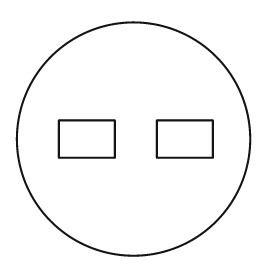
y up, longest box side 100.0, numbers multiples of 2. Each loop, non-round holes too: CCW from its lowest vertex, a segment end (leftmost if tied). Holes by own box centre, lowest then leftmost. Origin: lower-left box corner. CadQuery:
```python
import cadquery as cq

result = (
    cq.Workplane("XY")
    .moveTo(50.0, 50.0)
    .circle(50.0)
    .moveTo(18.0, 42.0)
    .lineTo(42.0, 42.0)
    .lineTo(42.0, 58.0)
    .lineTo(18.0, 58.0)
    .close()
    .moveTo(60.0, 42.0)
    .lineTo(84.0, 42.0)
    .lineTo(84.0, 58.0)
    .lineTo(60.0, 58.0)
    .close()
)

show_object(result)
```